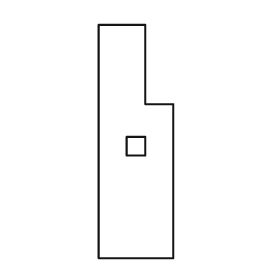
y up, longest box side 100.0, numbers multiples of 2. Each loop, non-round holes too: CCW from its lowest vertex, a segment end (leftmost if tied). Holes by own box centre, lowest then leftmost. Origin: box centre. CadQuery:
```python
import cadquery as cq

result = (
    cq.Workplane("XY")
    .moveTo(-16.0, -50.0)
    .lineTo(16.0, -50.0)
    .lineTo(16.0, 16.0)
    .lineTo(4.0, 16.0)
    .lineTo(4.0, 50.0)
    .lineTo(-16.0, 50.0)
    .close()
    .moveTo(-4.0, -6.0)
    .lineTo(4.0, -6.0)
    .lineTo(4.0, 2.0)
    .lineTo(-4.0, 2.0)
    .close()
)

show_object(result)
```